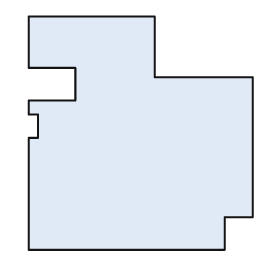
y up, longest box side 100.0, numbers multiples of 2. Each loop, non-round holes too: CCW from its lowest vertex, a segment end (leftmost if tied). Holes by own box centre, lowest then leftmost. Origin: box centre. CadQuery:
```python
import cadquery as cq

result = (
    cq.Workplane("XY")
    .moveTo(-48.0, -50.0)
    .lineTo(36.0, -50.0)
    .lineTo(36.0, -36.0)
    .lineTo(48.0, -36.0)
    .lineTo(48.0, 24.0)
    .lineTo(6.0, 24.0)
    .lineTo(6.0, 50.0)
    .lineTo(-48.0, 50.0)
    .lineTo(-48.0, 28.0)
    .lineTo(-28.0, 28.0)
    .lineTo(-28.0, 14.0)
    .lineTo(-48.0, 14.0)
    .lineTo(-48.0, 8.0)
    .lineTo(-44.0, 8.0)
    .lineTo(-44.0, -2.0)
    .lineTo(-48.0, -2.0)
    .close()
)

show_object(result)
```